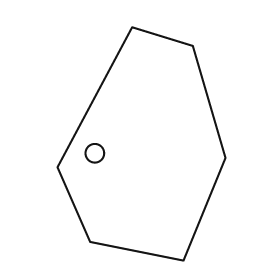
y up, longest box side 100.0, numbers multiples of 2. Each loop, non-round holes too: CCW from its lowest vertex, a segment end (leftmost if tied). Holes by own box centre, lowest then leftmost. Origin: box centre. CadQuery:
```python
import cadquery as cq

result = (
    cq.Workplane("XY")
    .moveTo(18.0, -50.0)
    .lineTo(36.0, -6.0)
    .lineTo(22.0, 42.0)
    .lineTo(-4.0, 50.0)
    .lineTo(-36.0, -10.0)
    .lineTo(-22.0, -42.0)
    .close()
    .moveTo(-20.0, -4.0)
    .circle(4.0)
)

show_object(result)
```